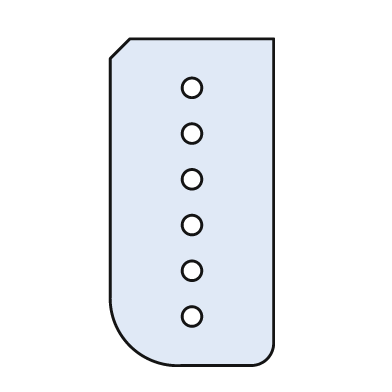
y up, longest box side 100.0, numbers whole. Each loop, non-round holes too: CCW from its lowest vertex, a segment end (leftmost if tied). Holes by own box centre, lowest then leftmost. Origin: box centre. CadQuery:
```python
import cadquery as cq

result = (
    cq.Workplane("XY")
    .moveTo(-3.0, -50.0)
    .lineTo(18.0, -50.0)
    .threePointArc((23.0, -48.0), (25.0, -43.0))
    .lineTo(25.0, 50.0)
    .lineTo(-19.0, 50.0)
    .lineTo(-25.0, 44.0)
    .lineTo(-25.0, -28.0)
    .threePointArc((-19.0, -44.0), (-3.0, -50.0))
    .close()
    .moveTo(0.0, -35.0)
    .circle(3.0)
    .moveTo(0.0, -21.0)
    .circle(3.0)
    .moveTo(0.0, -7.0)
    .circle(3.0)
    .moveTo(0.0, 7.0)
    .circle(3.0)
    .moveTo(0.0, 21.0)
    .circle(3.0)
    .moveTo(0.0, 35.0)
    .circle(3.0)
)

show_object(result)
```